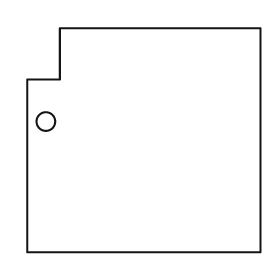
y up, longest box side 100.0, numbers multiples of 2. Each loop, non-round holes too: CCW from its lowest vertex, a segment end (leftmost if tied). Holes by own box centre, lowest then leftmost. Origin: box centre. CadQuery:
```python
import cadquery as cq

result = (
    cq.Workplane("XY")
    .moveTo(-50.0, -48.0)
    .lineTo(50.0, -48.0)
    .lineTo(50.0, 48.0)
    .lineTo(-36.0, 48.0)
    .lineTo(-36.0, 26.0)
    .lineTo(-50.0, 26.0)
    .close()
    .moveTo(-42.0, 8.0)
    .circle(4.0)
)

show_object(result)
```